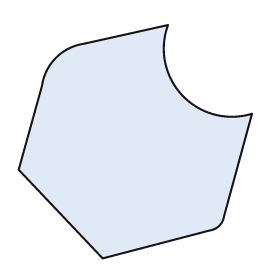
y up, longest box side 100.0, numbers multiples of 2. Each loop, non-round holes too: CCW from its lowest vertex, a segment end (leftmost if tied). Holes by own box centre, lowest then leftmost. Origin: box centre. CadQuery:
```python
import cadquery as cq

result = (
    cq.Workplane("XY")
    .moveTo(-14.0, -50.0)
    .lineTo(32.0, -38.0)
    .threePointArc((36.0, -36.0), (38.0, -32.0))
    .lineTo(50.0, 12.0)
    .threePointArc((20.0, 20.0), (14.0, 50.0))
    .lineTo(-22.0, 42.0)
    .threePointArc((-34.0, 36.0), (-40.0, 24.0))
    .lineTo(-50.0, -12.0)
    .close()
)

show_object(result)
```